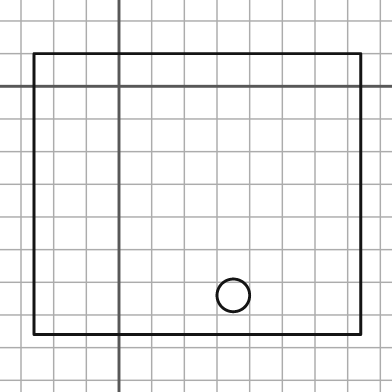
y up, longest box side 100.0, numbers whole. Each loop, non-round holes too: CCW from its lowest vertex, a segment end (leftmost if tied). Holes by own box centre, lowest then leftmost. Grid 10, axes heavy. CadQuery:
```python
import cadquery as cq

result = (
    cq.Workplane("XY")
    .moveTo(-26.0, -76.0)
    .lineTo(74.0, -76.0)
    .lineTo(74.0, 10.0)
    .lineTo(-26.0, 10.0)
    .close()
    .moveTo(35.0, -64.0)
    .circle(5.0)
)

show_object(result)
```